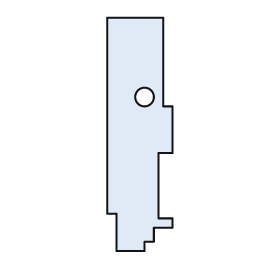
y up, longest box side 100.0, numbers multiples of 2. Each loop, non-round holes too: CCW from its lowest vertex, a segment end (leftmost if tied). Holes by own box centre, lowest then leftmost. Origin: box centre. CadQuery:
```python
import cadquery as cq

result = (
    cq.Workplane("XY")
    .moveTo(-10.0, -50.0)
    .lineTo(2.0, -50.0)
    .lineTo(2.0, -46.0)
    .lineTo(6.0, -46.0)
    .lineTo(6.0, -40.0)
    .lineTo(14.0, -40.0)
    .lineTo(14.0, -36.0)
    .lineTo(8.0, -36.0)
    .lineTo(8.0, -8.0)
    .lineTo(14.0, -8.0)
    .lineTo(14.0, 12.0)
    .lineTo(10.0, 12.0)
    .lineTo(10.0, 50.0)
    .lineTo(-14.0, 50.0)
    .lineTo(-14.0, -34.0)
    .lineTo(-10.0, -34.0)
    .close()
    .moveTo(2.0, 16.0)
    .circle(4.0)
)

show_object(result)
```